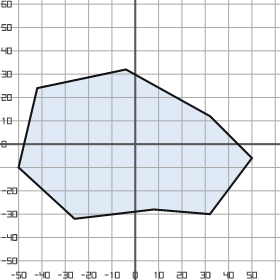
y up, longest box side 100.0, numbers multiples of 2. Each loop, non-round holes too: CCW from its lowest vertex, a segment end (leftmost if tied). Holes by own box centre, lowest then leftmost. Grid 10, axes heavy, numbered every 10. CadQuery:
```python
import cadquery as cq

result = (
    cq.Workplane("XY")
    .moveTo(-26.0, -32.0)
    .lineTo(8.0, -28.0)
    .lineTo(32.0, -30.0)
    .lineTo(50.0, -6.0)
    .lineTo(32.0, 12.0)
    .lineTo(-4.0, 32.0)
    .lineTo(-42.0, 24.0)
    .lineTo(-50.0, -10.0)
    .close()
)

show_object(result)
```